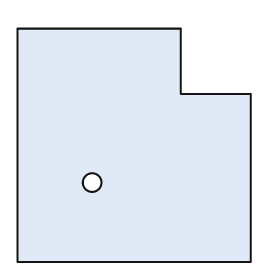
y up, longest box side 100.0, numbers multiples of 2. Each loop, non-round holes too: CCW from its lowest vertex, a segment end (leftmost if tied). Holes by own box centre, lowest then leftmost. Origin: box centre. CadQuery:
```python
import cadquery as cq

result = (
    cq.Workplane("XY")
    .moveTo(-50.0, -50.0)
    .lineTo(50.0, -50.0)
    .lineTo(50.0, 22.0)
    .lineTo(20.0, 22.0)
    .lineTo(20.0, 50.0)
    .lineTo(-50.0, 50.0)
    .close()
    .moveTo(-18.0, -16.0)
    .circle(4.0)
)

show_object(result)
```